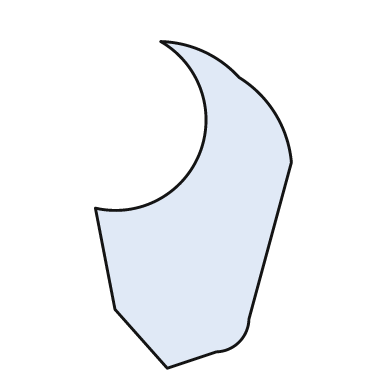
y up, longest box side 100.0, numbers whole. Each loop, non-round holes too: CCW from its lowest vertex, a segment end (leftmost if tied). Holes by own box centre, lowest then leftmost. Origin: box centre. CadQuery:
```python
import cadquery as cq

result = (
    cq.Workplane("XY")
    .moveTo(-8.0, -50.0)
    .lineTo(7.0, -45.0)
    .threePointArc((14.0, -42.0), (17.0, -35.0))
    .lineTo(30.0, 13.0)
    .threePointArc((25.0, 28.0), (14.0, 39.0))
    .threePointArc((3.0, 47.0), (-10.0, 50.0))
    .threePointArc((2.0, 16.0), (-30.0, -1.0))
    .lineTo(-24.0, -32.0)
    .close()
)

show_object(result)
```